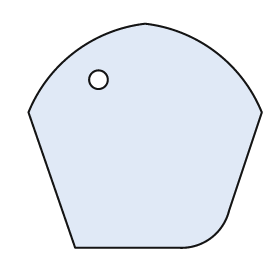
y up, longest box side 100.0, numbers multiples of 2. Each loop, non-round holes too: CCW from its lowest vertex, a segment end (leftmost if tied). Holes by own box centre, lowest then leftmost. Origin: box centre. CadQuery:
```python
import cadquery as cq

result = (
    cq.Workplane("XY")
    .moveTo(-30.0, -48.0)
    .lineTo(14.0, -48.0)
    .threePointArc((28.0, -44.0), (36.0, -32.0))
    .lineTo(50.0, 10.0)
    .threePointArc((30.0, 36.0), (0.0, 48.0))
    .threePointArc((-30.0, 36.0), (-50.0, 10.0))
    .close()
    .moveTo(-20.0, 24.0)
    .circle(4.0)
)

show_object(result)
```